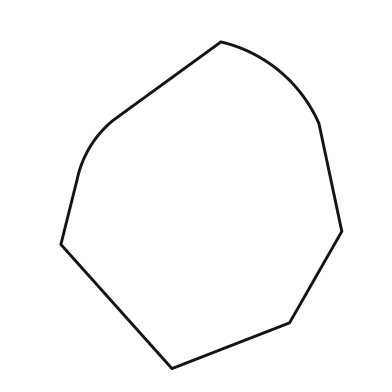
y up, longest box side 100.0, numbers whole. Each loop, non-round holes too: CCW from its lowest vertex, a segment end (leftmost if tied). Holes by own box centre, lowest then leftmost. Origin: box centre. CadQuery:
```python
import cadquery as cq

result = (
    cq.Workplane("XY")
    .moveTo(-9.0, -50.0)
    .lineTo(27.0, -36.0)
    .lineTo(43.0, -8.0)
    .lineTo(36.0, 25.0)
    .threePointArc((24.0, 41.0), (6.0, 50.0))
    .lineTo(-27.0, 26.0)
    .threePointArc((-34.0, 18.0), (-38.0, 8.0))
    .lineTo(-43.0, -12.0)
    .close()
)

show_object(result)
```